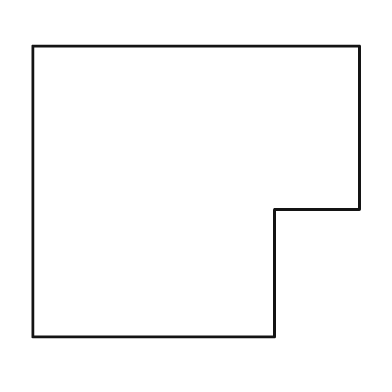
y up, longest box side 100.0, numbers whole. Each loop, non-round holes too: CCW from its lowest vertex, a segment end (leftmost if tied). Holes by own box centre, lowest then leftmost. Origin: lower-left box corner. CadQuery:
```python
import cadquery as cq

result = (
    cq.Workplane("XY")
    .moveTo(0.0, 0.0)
    .lineTo(74.0, 0.0)
    .lineTo(74.0, 39.0)
    .lineTo(100.0, 39.0)
    .lineTo(100.0, 89.0)
    .lineTo(0.0, 89.0)
    .close()
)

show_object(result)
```